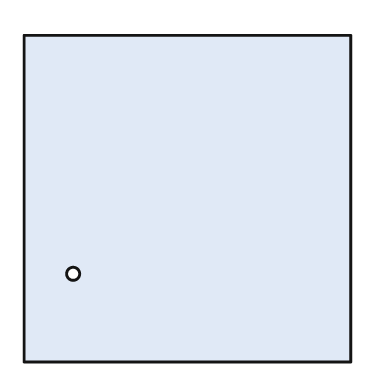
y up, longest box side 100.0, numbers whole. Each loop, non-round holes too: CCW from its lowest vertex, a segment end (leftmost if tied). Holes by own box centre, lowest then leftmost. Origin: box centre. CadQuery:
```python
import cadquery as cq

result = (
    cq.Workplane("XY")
    .moveTo(-50.0, -50.0)
    .lineTo(50.0, -50.0)
    .lineTo(50.0, 50.0)
    .lineTo(-50.0, 50.0)
    .close()
    .moveTo(-35.0, -23.0)
    .circle(2.0)
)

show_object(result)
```